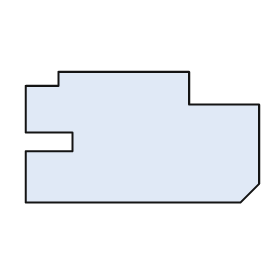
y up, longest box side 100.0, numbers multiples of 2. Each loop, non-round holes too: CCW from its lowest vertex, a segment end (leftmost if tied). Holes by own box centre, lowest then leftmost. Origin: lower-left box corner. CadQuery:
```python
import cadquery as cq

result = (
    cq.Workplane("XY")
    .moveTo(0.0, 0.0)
    .lineTo(92.0, 0.0)
    .lineTo(100.0, 8.0)
    .lineTo(100.0, 42.0)
    .lineTo(70.0, 42.0)
    .lineTo(70.0, 56.0)
    .lineTo(14.0, 56.0)
    .lineTo(14.0, 50.0)
    .lineTo(0.0, 50.0)
    .lineTo(0.0, 30.0)
    .lineTo(20.0, 30.0)
    .lineTo(20.0, 22.0)
    .lineTo(0.0, 22.0)
    .close()
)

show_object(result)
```